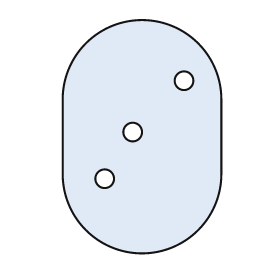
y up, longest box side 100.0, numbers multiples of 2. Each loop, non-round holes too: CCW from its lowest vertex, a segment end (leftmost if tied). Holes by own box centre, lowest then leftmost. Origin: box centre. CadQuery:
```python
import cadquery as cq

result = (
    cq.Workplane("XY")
    .moveTo(-34.0, -16.0)
    .threePointArc((0.0, -50.0), (34.0, -16.0))
    .lineTo(34.0, 16.0)
    .threePointArc((0.0, 50.0), (-34.0, 16.0))
    .close()
    .moveTo(-16.0, -18.0)
    .circle(4.0)
    .moveTo(-4.0, 2.0)
    .circle(4.0)
    .moveTo(18.0, 24.0)
    .circle(4.0)
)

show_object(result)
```